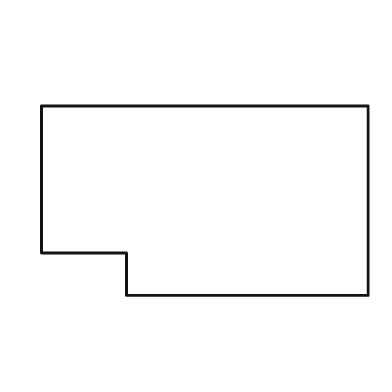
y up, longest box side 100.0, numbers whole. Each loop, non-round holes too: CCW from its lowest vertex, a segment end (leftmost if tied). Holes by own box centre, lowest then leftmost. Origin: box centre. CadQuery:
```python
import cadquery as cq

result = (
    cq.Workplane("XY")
    .moveTo(-24.0, -29.0)
    .lineTo(50.0, -29.0)
    .lineTo(50.0, 29.0)
    .lineTo(-50.0, 29.0)
    .lineTo(-50.0, -16.0)
    .lineTo(-24.0, -16.0)
    .close()
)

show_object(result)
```